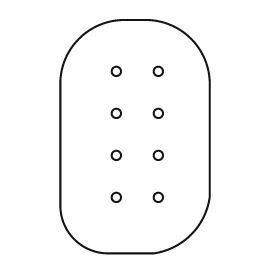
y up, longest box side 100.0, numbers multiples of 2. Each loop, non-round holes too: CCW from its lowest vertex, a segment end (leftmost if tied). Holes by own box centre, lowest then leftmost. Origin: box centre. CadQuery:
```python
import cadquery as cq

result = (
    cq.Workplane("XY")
    .moveTo(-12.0, -50.0)
    .lineTo(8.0, -50.0)
    .threePointArc((24.0, -42.0), (32.0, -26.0))
    .lineTo(32.0, 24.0)
    .threePointArc((24.0, 42.0), (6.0, 50.0))
    .lineTo(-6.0, 50.0)
    .threePointArc((-24.0, 42.0), (-32.0, 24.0))
    .lineTo(-32.0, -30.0)
    .threePointArc((-26.0, -44.0), (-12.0, -50.0))
    .close()
    .moveTo(-8.0, -26.0)
    .circle(2.0)
    .moveTo(10.0, -26.0)
    .circle(2.0)
    .moveTo(-8.0, -8.0)
    .circle(2.0)
    .moveTo(10.0, -8.0)
    .circle(2.0)
    .moveTo(-8.0, 10.0)
    .circle(2.0)
    .moveTo(10.0, 10.0)
    .circle(2.0)
    .moveTo(-8.0, 28.0)
    .circle(2.0)
    .moveTo(10.0, 28.0)
    .circle(2.0)
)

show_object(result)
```